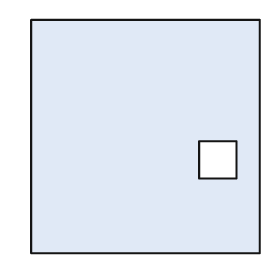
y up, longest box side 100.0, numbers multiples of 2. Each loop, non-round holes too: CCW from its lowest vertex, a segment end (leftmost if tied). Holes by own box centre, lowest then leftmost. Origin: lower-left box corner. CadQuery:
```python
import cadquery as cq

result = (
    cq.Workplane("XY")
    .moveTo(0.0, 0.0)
    .lineTo(98.0, 0.0)
    .lineTo(98.0, 100.0)
    .lineTo(0.0, 100.0)
    .close()
    .moveTo(72.0, 32.0)
    .lineTo(88.0, 32.0)
    .lineTo(88.0, 48.0)
    .lineTo(72.0, 48.0)
    .close()
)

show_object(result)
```